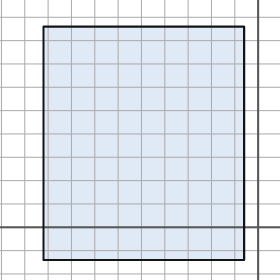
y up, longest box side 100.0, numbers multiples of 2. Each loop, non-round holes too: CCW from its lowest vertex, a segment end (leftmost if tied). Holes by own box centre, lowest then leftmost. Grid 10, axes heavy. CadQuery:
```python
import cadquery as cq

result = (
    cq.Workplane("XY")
    .moveTo(-92.0, -14.0)
    .lineTo(-6.0, -14.0)
    .lineTo(-6.0, 86.0)
    .lineTo(-92.0, 86.0)
    .close()
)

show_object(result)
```